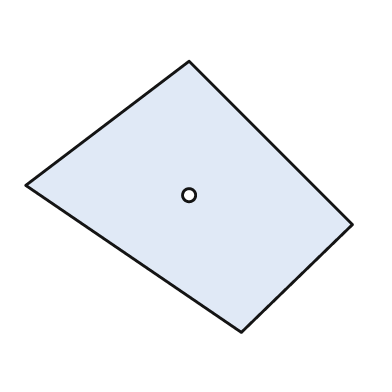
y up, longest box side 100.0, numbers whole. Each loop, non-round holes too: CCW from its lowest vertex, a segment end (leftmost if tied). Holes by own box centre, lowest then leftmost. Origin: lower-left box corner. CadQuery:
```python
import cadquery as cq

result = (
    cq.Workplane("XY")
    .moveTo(66.0, 0.0)
    .lineTo(100.0, 33.0)
    .lineTo(50.0, 83.0)
    .lineTo(0.0, 45.0)
    .close()
    .moveTo(50.0, 42.0)
    .circle(2.0)
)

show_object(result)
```